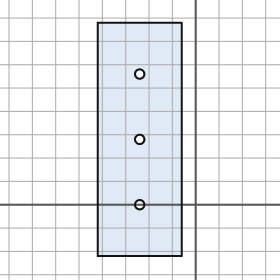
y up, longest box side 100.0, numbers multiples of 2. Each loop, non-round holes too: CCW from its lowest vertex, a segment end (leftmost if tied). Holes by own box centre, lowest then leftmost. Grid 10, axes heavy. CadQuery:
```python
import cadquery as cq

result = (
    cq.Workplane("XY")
    .moveTo(-42.0, -22.0)
    .lineTo(-6.0, -22.0)
    .lineTo(-6.0, 78.0)
    .lineTo(-42.0, 78.0)
    .close()
    .moveTo(-24.0, 0.0)
    .circle(2.0)
    .moveTo(-24.0, 28.0)
    .circle(2.0)
    .moveTo(-24.0, 56.0)
    .circle(2.0)
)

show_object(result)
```